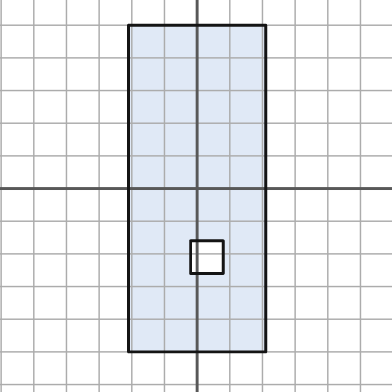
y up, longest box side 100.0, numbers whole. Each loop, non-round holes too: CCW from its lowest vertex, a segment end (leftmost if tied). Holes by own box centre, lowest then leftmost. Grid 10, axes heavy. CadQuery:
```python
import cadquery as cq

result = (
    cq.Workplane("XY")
    .moveTo(-21.0, -50.0)
    .lineTo(21.0, -50.0)
    .lineTo(21.0, 50.0)
    .lineTo(-21.0, 50.0)
    .close()
    .moveTo(-2.0, -26.0)
    .lineTo(8.0, -26.0)
    .lineTo(8.0, -16.0)
    .lineTo(-2.0, -16.0)
    .close()
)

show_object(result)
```